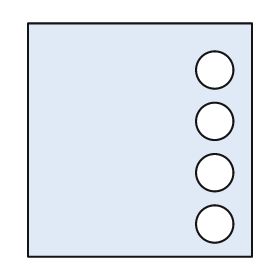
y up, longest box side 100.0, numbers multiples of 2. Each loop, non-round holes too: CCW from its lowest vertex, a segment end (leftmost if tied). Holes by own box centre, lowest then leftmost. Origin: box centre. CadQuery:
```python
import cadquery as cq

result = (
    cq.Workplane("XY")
    .moveTo(-48.0, -50.0)
    .lineTo(48.0, -50.0)
    .lineTo(48.0, 50.0)
    .lineTo(-48.0, 50.0)
    .close()
    .moveTo(32.0, -36.0)
    .circle(8.0)
    .moveTo(32.0, -14.0)
    .circle(8.0)
    .moveTo(32.0, 8.0)
    .circle(8.0)
    .moveTo(32.0, 30.0)
    .circle(8.0)
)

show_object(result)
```